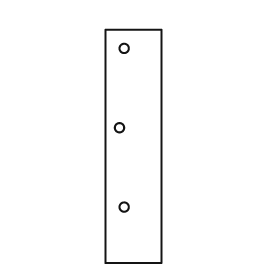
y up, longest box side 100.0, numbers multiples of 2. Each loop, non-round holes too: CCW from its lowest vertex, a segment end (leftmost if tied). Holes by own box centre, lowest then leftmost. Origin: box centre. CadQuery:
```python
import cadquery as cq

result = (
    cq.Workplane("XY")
    .moveTo(-12.0, -50.0)
    .lineTo(12.0, -50.0)
    .lineTo(12.0, 50.0)
    .lineTo(-12.0, 50.0)
    .close()
    .moveTo(-4.0, -26.0)
    .circle(2.0)
    .moveTo(-6.0, 8.0)
    .circle(2.0)
    .moveTo(-4.0, 42.0)
    .circle(2.0)
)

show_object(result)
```